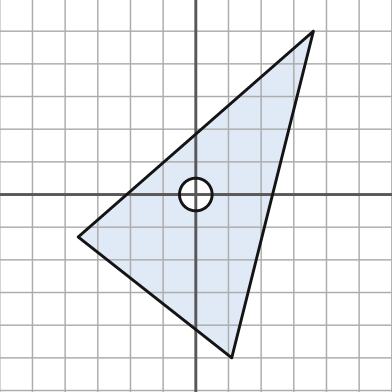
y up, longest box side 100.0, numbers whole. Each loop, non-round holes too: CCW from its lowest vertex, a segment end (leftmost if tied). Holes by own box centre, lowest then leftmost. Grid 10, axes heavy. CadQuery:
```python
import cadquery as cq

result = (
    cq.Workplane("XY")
    .moveTo(11.0, -50.0)
    .lineTo(36.0, 50.0)
    .lineTo(-36.0, -13.0)
    .close()
    .moveTo(0.0, 0.0)
    .circle(5.0)
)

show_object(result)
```